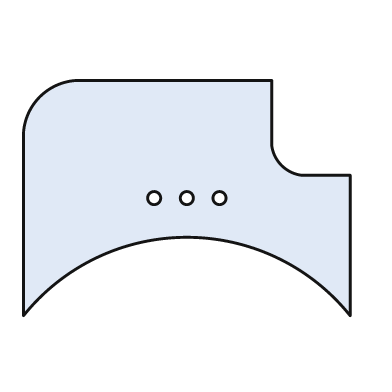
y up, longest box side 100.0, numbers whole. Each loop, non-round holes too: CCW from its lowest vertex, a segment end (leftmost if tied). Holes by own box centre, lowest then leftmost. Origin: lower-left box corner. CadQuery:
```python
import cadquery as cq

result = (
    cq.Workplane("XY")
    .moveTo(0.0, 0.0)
    .threePointArc((50.0, 24.0), (100.0, 0.0))
    .lineTo(100.0, 43.0)
    .lineTo(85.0, 43.0)
    .threePointArc((79.0, 46.0), (76.0, 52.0))
    .lineTo(76.0, 72.0)
    .lineTo(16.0, 72.0)
    .threePointArc((5.0, 67.0), (0.0, 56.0))
    .close()
    .moveTo(40.0, 36.0)
    .circle(2.0)
    .moveTo(50.0, 36.0)
    .circle(2.0)
    .moveTo(60.0, 36.0)
    .circle(2.0)
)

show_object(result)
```